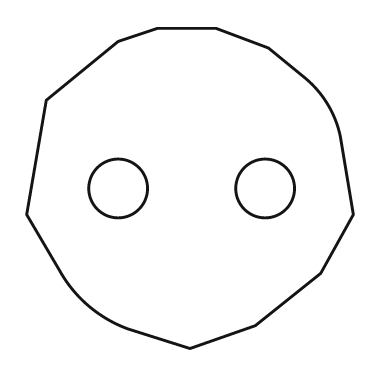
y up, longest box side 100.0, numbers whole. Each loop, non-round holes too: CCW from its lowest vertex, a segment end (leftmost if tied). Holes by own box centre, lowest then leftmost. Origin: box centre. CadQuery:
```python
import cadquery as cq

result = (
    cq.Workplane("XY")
    .moveTo(0.0, -49.0)
    .lineTo(20.0, -42.0)
    .lineTo(40.0, -26.0)
    .lineTo(50.0, -8.0)
    .lineTo(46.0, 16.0)
    .threePointArc((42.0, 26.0), (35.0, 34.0))
    .lineTo(24.0, 43.0)
    .lineTo(8.0, 49.0)
    .lineTo(-10.0, 49.0)
    .lineTo(-22.0, 45.0)
    .lineTo(-44.0, 27.0)
    .lineTo(-50.0, -8.0)
    .lineTo(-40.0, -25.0)
    .threePointArc((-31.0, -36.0), (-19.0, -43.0))
    .close()
    .moveTo(-22.0, 0.0)
    .circle(9.0)
    .moveTo(23.0, 0.0)
    .circle(9.0)
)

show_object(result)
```